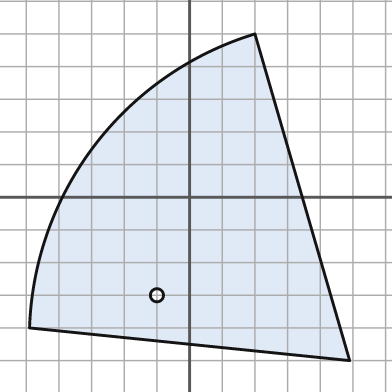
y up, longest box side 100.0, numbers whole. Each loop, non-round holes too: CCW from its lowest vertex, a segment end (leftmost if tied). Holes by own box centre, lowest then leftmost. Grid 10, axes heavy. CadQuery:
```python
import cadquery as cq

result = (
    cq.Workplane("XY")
    .moveTo(49.0, -50.0)
    .lineTo(20.0, 50.0)
    .threePointArc((-29.0, 16.0), (-49.0, -40.0))
    .close()
    .moveTo(-10.0, -30.0)
    .circle(2.0)
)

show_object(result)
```